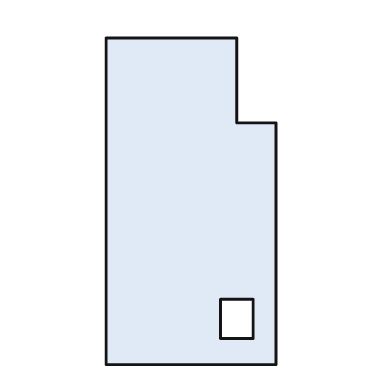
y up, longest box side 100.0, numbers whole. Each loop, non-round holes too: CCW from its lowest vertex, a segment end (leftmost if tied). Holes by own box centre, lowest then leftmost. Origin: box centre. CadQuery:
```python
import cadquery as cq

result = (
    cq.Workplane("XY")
    .moveTo(-26.0, -50.0)
    .lineTo(26.0, -50.0)
    .lineTo(26.0, 24.0)
    .lineTo(14.0, 24.0)
    .lineTo(14.0, 50.0)
    .lineTo(-26.0, 50.0)
    .close()
    .moveTo(9.0, -42.0)
    .lineTo(19.0, -42.0)
    .lineTo(19.0, -30.0)
    .lineTo(9.0, -30.0)
    .close()
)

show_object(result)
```